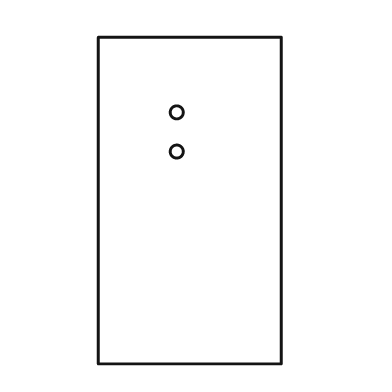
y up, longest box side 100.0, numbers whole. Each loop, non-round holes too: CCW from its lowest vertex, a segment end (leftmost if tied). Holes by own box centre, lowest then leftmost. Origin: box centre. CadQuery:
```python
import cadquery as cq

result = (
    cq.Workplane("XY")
    .moveTo(-28.0, -50.0)
    .lineTo(28.0, -50.0)
    .lineTo(28.0, 50.0)
    .lineTo(-28.0, 50.0)
    .close()
    .moveTo(-4.0, 15.0)
    .circle(2.0)
    .moveTo(-4.0, 27.0)
    .circle(2.0)
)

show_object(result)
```